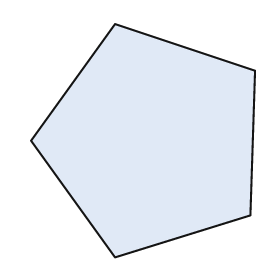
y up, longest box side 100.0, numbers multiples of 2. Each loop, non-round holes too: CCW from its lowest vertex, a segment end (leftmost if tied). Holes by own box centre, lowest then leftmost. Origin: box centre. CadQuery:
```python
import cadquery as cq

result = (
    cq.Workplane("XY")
    .moveTo(-12.0, -50.0)
    .lineTo(46.0, -32.0)
    .lineTo(48.0, 30.0)
    .lineTo(-12.0, 50.0)
    .lineTo(-48.0, 0.0)
    .close()
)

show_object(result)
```